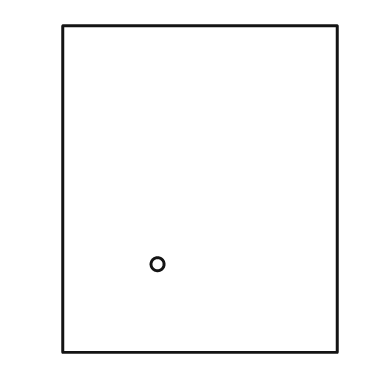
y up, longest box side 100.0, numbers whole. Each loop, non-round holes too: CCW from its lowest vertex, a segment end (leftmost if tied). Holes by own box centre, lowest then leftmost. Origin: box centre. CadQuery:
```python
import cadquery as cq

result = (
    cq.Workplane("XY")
    .moveTo(-42.0, -50.0)
    .lineTo(42.0, -50.0)
    .lineTo(42.0, 50.0)
    .lineTo(-42.0, 50.0)
    .close()
    .moveTo(-13.0, -23.0)
    .circle(2.0)
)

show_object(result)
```